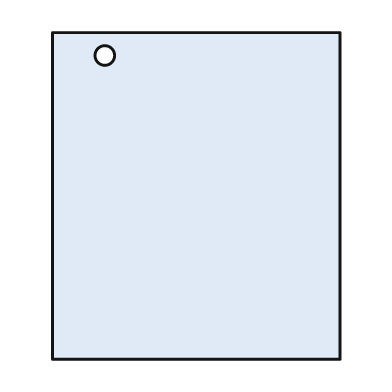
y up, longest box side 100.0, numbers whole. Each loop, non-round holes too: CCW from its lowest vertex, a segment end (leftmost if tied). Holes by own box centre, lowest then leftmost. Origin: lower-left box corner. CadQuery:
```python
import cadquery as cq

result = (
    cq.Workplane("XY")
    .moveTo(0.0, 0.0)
    .lineTo(88.0, 0.0)
    .lineTo(88.0, 100.0)
    .lineTo(0.0, 100.0)
    .close()
    .moveTo(16.0, 93.0)
    .circle(3.0)
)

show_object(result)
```